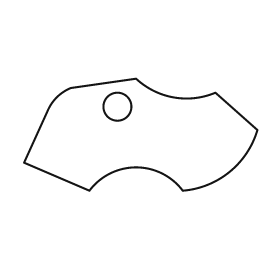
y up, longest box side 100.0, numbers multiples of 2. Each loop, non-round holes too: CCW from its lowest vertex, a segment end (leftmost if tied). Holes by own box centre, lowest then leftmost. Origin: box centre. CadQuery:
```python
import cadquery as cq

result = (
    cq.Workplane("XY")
    .moveTo(-22.0, -24.0)
    .threePointArc((-2.0, -14.0), (18.0, -24.0))
    .threePointArc((38.0, -16.0), (50.0, 2.0))
    .lineTo(32.0, 18.0)
    .threePointArc((14.0, 16.0), (-2.0, 24.0))
    .lineTo(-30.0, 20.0)
    .threePointArc((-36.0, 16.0), (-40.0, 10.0))
    .lineTo(-50.0, -12.0)
    .close()
    .moveTo(-10.0, 12.0)
    .circle(6.0)
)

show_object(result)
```